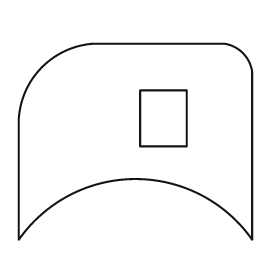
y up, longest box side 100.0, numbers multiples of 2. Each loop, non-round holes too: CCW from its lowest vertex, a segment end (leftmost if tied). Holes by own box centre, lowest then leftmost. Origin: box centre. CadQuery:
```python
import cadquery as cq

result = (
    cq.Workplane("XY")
    .moveTo(-50.0, -42.0)
    .threePointArc((0.0, -16.0), (50.0, -42.0))
    .lineTo(50.0, 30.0)
    .threePointArc((46.0, 38.0), (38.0, 42.0))
    .lineTo(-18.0, 42.0)
    .threePointArc((-40.0, 32.0), (-50.0, 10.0))
    .close()
    .moveTo(2.0, -2.0)
    .lineTo(22.0, -2.0)
    .lineTo(22.0, 22.0)
    .lineTo(2.0, 22.0)
    .close()
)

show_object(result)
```